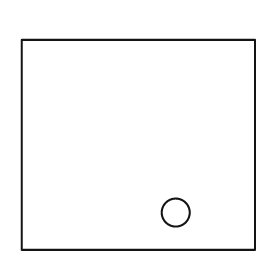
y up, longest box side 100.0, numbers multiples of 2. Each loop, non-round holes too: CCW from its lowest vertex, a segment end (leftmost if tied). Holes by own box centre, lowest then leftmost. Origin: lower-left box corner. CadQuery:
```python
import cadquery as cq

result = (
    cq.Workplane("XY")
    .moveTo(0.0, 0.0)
    .lineTo(100.0, 0.0)
    .lineTo(100.0, 90.0)
    .lineTo(0.0, 90.0)
    .close()
    .moveTo(66.0, 16.0)
    .circle(6.0)
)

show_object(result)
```